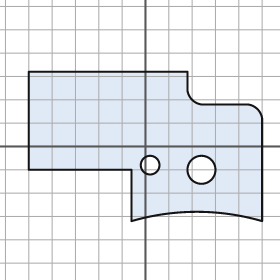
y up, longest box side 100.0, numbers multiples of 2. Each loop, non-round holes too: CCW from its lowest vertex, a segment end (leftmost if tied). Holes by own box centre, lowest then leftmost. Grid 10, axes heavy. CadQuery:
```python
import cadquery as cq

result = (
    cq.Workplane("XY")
    .moveTo(-6.0, -32.0)
    .threePointArc((22.0, -28.0), (50.0, -32.0))
    .lineTo(50.0, 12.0)
    .threePointArc((48.0, 16.0), (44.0, 18.0))
    .lineTo(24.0, 18.0)
    .threePointArc((20.0, 20.0), (18.0, 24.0))
    .lineTo(18.0, 32.0)
    .lineTo(-50.0, 32.0)
    .lineTo(-50.0, -10.0)
    .lineTo(-6.0, -10.0)
    .close()
    .moveTo(24.0, -10.0)
    .circle(6.0)
    .moveTo(2.0, -8.0)
    .circle(4.0)
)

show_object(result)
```